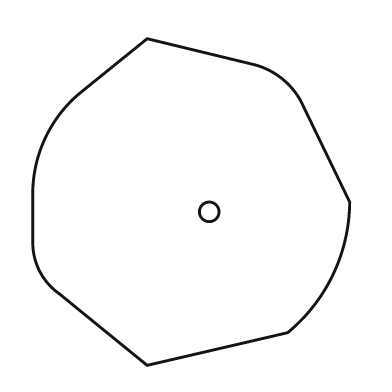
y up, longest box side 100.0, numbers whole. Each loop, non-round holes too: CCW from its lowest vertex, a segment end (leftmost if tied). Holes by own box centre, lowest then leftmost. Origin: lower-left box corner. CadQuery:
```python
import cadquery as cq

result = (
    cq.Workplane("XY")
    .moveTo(35.0, 0.0)
    .lineTo(78.0, 10.0)
    .threePointArc((92.0, 28.0), (97.0, 50.0))
    .lineTo(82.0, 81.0)
    .threePointArc((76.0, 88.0), (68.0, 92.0))
    .lineTo(35.0, 100.0)
    .lineTo(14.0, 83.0)
    .threePointArc((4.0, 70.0), (0.0, 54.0))
    .lineTo(0.0, 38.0)
    .threePointArc((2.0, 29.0), (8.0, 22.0))
    .close()
    .moveTo(54.0, 47.0)
    .circle(3.0)
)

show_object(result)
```